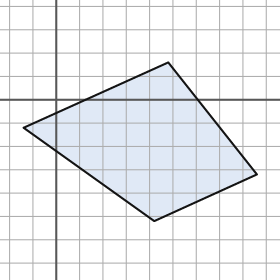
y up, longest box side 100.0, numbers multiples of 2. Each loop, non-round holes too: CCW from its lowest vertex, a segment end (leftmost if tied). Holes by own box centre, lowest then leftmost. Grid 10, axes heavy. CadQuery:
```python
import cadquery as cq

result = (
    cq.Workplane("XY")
    .moveTo(42.0, -52.0)
    .lineTo(86.0, -32.0)
    .lineTo(48.0, 16.0)
    .lineTo(-14.0, -12.0)
    .close()
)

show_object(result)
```